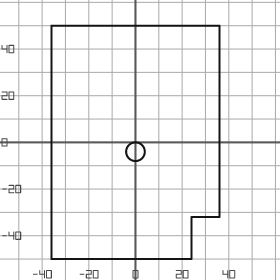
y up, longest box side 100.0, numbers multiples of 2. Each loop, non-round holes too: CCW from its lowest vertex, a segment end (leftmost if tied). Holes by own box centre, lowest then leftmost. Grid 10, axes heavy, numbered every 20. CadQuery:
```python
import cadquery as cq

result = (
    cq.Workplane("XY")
    .moveTo(-36.0, -50.0)
    .lineTo(24.0, -50.0)
    .lineTo(24.0, -32.0)
    .lineTo(36.0, -32.0)
    .lineTo(36.0, 50.0)
    .lineTo(-36.0, 50.0)
    .close()
    .moveTo(0.0, -4.0)
    .circle(4.0)
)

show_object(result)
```